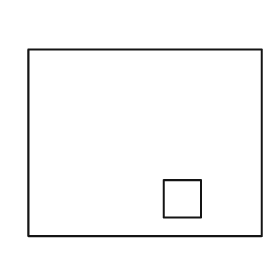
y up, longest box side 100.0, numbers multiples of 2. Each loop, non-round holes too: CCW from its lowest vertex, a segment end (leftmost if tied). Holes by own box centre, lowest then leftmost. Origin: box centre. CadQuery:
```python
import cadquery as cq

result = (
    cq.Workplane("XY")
    .moveTo(-50.0, -40.0)
    .lineTo(50.0, -40.0)
    .lineTo(50.0, 40.0)
    .lineTo(-50.0, 40.0)
    .close()
    .moveTo(8.0, -32.0)
    .lineTo(24.0, -32.0)
    .lineTo(24.0, -16.0)
    .lineTo(8.0, -16.0)
    .close()
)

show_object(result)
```